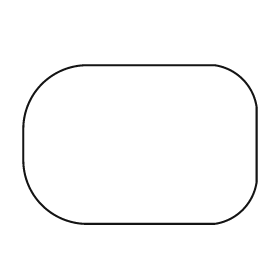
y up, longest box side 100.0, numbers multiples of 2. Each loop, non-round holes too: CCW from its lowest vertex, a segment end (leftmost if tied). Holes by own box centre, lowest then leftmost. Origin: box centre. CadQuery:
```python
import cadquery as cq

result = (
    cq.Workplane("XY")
    .moveTo(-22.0, -34.0)
    .lineTo(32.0, -34.0)
    .threePointArc((44.0, -28.0), (50.0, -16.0))
    .lineTo(50.0, 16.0)
    .threePointArc((44.0, 28.0), (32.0, 34.0))
    .lineTo(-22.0, 34.0)
    .threePointArc((-42.0, 26.0), (-50.0, 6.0))
    .lineTo(-50.0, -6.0)
    .threePointArc((-42.0, -26.0), (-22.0, -34.0))
    .close()
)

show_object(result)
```